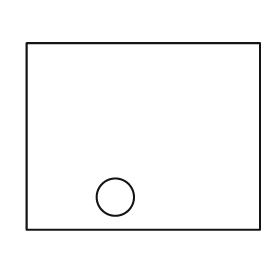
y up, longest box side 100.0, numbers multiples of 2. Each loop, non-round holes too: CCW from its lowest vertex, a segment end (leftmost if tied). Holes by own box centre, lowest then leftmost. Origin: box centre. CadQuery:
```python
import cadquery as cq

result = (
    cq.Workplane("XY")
    .moveTo(-50.0, -40.0)
    .lineTo(50.0, -40.0)
    .lineTo(50.0, 40.0)
    .lineTo(-50.0, 40.0)
    .close()
    .moveTo(-12.0, -26.0)
    .circle(8.0)
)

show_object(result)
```